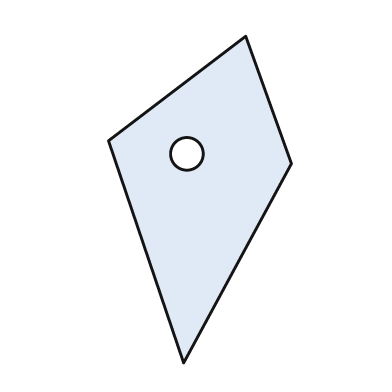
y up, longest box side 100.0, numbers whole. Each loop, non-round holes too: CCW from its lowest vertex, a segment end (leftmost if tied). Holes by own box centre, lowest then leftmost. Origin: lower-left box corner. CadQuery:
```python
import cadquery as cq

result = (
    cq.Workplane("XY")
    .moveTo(23.0, 0.0)
    .lineTo(56.0, 61.0)
    .lineTo(42.0, 100.0)
    .lineTo(0.0, 68.0)
    .close()
    .moveTo(24.0, 64.0)
    .circle(5.0)
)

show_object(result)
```